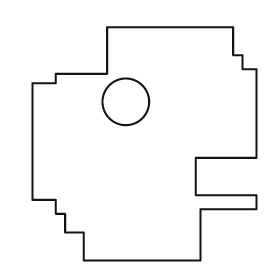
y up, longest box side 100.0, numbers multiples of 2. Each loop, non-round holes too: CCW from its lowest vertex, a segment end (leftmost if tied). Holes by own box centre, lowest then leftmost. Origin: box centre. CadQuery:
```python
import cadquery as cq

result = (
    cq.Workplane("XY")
    .moveTo(-26.0, -50.0)
    .lineTo(24.0, -50.0)
    .lineTo(24.0, -28.0)
    .lineTo(48.0, -28.0)
    .lineTo(48.0, -22.0)
    .lineTo(22.0, -22.0)
    .lineTo(22.0, -6.0)
    .lineTo(48.0, -6.0)
    .lineTo(48.0, 32.0)
    .lineTo(42.0, 32.0)
    .lineTo(42.0, 38.0)
    .lineTo(38.0, 38.0)
    .lineTo(38.0, 50.0)
    .lineTo(-16.0, 50.0)
    .lineTo(-16.0, 30.0)
    .lineTo(-38.0, 30.0)
    .lineTo(-38.0, 26.0)
    .lineTo(-48.0, 26.0)
    .lineTo(-48.0, -24.0)
    .lineTo(-38.0, -24.0)
    .lineTo(-38.0, -30.0)
    .lineTo(-34.0, -30.0)
    .lineTo(-34.0, -38.0)
    .lineTo(-26.0, -38.0)
    .close()
    .moveTo(-8.0, 18.0)
    .circle(10.0)
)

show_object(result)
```